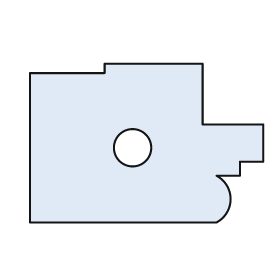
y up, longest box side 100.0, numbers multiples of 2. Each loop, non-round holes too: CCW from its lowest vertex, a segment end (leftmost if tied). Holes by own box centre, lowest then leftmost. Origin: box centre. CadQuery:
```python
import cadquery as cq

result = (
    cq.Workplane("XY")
    .moveTo(-50.0, -34.0)
    .lineTo(30.0, -34.0)
    .threePointArc((36.0, -24.0), (30.0, -14.0))
    .lineTo(40.0, -14.0)
    .lineTo(40.0, -8.0)
    .lineTo(50.0, -8.0)
    .lineTo(50.0, 8.0)
    .lineTo(24.0, 8.0)
    .lineTo(24.0, 34.0)
    .lineTo(-18.0, 34.0)
    .lineTo(-18.0, 30.0)
    .lineTo(-50.0, 30.0)
    .close()
    .moveTo(-6.0, -2.0)
    .circle(8.0)
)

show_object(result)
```